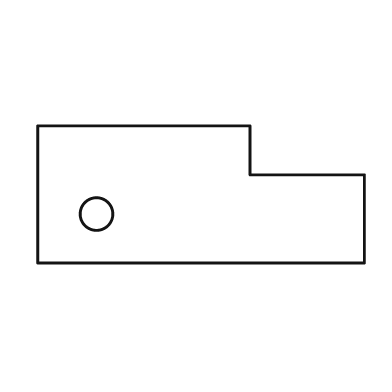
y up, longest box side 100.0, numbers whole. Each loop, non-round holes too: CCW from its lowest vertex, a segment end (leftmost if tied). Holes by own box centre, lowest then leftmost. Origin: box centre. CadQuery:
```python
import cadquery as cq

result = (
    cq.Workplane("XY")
    .moveTo(-50.0, -21.0)
    .lineTo(50.0, -21.0)
    .lineTo(50.0, 6.0)
    .lineTo(15.0, 6.0)
    .lineTo(15.0, 21.0)
    .lineTo(-50.0, 21.0)
    .close()
    .moveTo(-32.0, -6.0)
    .circle(5.0)
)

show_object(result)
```